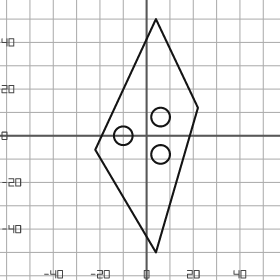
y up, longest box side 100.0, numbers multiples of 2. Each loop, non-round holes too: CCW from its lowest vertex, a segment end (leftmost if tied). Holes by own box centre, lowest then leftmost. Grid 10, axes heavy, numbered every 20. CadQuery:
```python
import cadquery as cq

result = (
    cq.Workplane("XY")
    .moveTo(4.0, -50.0)
    .lineTo(22.0, 12.0)
    .lineTo(4.0, 50.0)
    .lineTo(-22.0, -6.0)
    .close()
    .moveTo(6.0, -8.0)
    .circle(4.0)
    .moveTo(-10.0, 0.0)
    .circle(4.0)
    .moveTo(6.0, 8.0)
    .circle(4.0)
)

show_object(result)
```